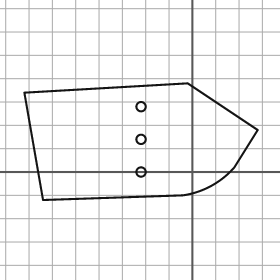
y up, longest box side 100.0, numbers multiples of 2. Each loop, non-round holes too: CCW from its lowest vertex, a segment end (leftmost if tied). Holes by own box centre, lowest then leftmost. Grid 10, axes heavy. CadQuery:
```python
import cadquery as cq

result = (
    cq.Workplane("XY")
    .moveTo(-64.0, -12.0)
    .lineTo(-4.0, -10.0)
    .threePointArc((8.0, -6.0), (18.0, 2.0))
    .lineTo(28.0, 18.0)
    .lineTo(-2.0, 38.0)
    .lineTo(-72.0, 34.0)
    .close()
    .moveTo(-22.0, 0.0)
    .circle(2.0)
    .moveTo(-22.0, 14.0)
    .circle(2.0)
    .moveTo(-22.0, 28.0)
    .circle(2.0)
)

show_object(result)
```